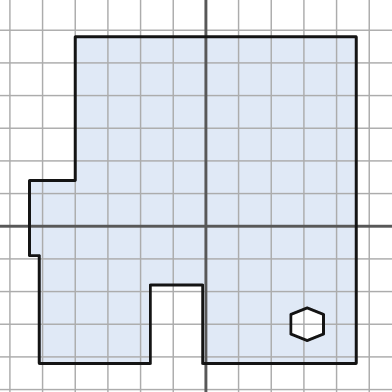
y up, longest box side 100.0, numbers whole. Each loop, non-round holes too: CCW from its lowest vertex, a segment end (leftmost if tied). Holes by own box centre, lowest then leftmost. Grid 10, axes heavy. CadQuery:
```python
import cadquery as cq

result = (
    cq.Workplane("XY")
    .moveTo(-51.0, -42.0)
    .lineTo(-17.0, -42.0)
    .lineTo(-17.0, -18.0)
    .lineTo(-1.0, -18.0)
    .lineTo(-1.0, -42.0)
    .lineTo(46.0, -42.0)
    .lineTo(46.0, 58.0)
    .lineTo(-40.0, 58.0)
    .lineTo(-40.0, 14.0)
    .lineTo(-54.0, 14.0)
    .lineTo(-54.0, -9.0)
    .lineTo(-51.0, -9.0)
    .close()
    .moveTo(31.0, -35.0)
    .lineTo(36.0, -33.0)
    .lineTo(36.0, -27.0)
    .lineTo(31.0, -25.0)
    .lineTo(26.0, -27.0)
    .lineTo(26.0, -33.0)
    .close()
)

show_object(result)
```